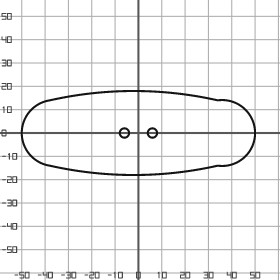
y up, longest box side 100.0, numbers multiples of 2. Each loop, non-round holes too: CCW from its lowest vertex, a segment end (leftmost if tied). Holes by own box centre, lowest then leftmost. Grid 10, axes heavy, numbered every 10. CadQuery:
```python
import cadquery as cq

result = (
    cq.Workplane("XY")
    .moveTo(-38.0, -14.0)
    .threePointArc((-2.0, -18.0), (34.0, -14.0))
    .threePointArc((50.0, 0.0), (34.0, 14.0))
    .threePointArc((-2.0, 18.0), (-38.0, 14.0))
    .threePointArc((-50.0, 0.0), (-38.0, -14.0))
    .close()
    .moveTo(-6.0, 0.0)
    .circle(2.0)
    .moveTo(6.0, 0.0)
    .circle(2.0)
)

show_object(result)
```